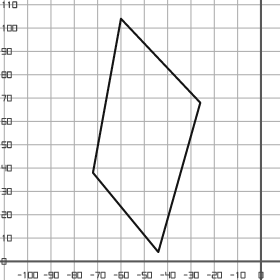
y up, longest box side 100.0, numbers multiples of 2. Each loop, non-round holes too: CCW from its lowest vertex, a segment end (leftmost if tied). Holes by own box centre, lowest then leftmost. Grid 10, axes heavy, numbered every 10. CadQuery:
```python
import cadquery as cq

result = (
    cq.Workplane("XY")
    .moveTo(-44.0, 4.0)
    .lineTo(-26.0, 68.0)
    .lineTo(-60.0, 104.0)
    .lineTo(-72.0, 38.0)
    .close()
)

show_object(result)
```